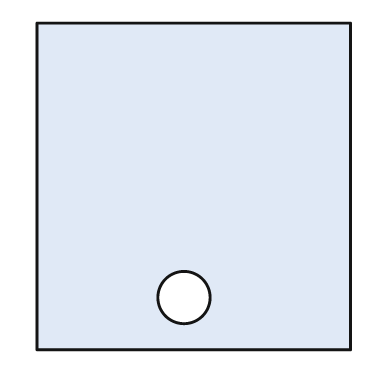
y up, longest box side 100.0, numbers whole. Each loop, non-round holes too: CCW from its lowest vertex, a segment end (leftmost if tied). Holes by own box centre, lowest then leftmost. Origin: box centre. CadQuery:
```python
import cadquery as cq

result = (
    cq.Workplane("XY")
    .moveTo(-48.0, -50.0)
    .lineTo(48.0, -50.0)
    .lineTo(48.0, 50.0)
    .lineTo(-48.0, 50.0)
    .close()
    .moveTo(-3.0, -34.0)
    .circle(8.0)
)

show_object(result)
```